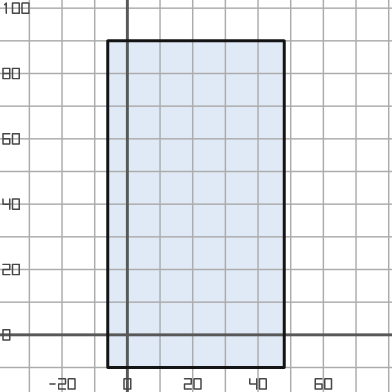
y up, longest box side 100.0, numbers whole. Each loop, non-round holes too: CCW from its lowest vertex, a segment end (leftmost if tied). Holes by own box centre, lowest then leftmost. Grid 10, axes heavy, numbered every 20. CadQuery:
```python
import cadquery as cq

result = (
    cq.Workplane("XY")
    .moveTo(-6.0, -10.0)
    .lineTo(48.0, -10.0)
    .lineTo(48.0, 90.0)
    .lineTo(-6.0, 90.0)
    .close()
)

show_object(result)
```